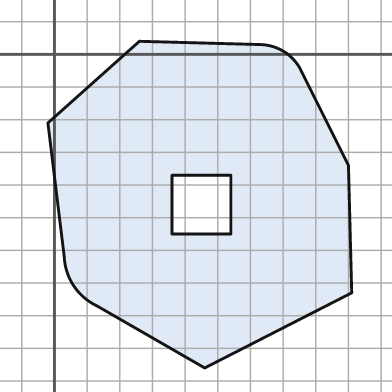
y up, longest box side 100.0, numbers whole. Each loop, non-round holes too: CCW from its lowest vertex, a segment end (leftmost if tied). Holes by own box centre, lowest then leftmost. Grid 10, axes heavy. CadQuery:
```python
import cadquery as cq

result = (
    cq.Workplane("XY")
    .moveTo(46.0, -96.0)
    .lineTo(91.0, -73.0)
    .lineTo(90.0, -34.0)
    .lineTo(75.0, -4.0)
    .threePointArc((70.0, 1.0), (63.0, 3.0))
    .lineTo(26.0, 4.0)
    .lineTo(-2.0, -21.0)
    .lineTo(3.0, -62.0)
    .threePointArc((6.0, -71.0), (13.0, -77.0))
    .close()
    .moveTo(36.0, -55.0)
    .lineTo(54.0, -55.0)
    .lineTo(54.0, -37.0)
    .lineTo(36.0, -37.0)
    .close()
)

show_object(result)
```